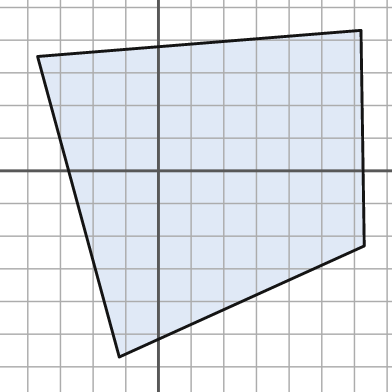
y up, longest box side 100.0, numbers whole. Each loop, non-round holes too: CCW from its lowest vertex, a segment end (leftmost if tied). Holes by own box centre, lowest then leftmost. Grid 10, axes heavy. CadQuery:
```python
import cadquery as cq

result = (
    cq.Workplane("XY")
    .moveTo(-12.0, -57.0)
    .lineTo(63.0, -23.0)
    .lineTo(62.0, 43.0)
    .lineTo(-37.0, 35.0)
    .close()
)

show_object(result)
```